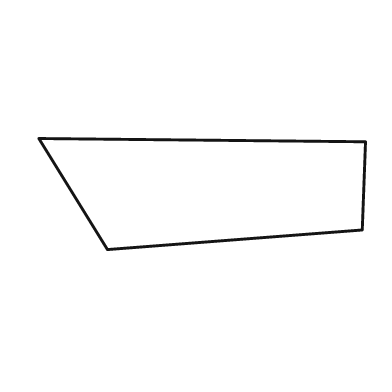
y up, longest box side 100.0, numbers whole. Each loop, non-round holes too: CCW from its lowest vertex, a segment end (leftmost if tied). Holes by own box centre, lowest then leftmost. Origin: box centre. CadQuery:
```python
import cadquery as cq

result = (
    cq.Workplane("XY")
    .moveTo(-29.0, -17.0)
    .lineTo(49.0, -11.0)
    .lineTo(50.0, 16.0)
    .lineTo(-50.0, 17.0)
    .close()
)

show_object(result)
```